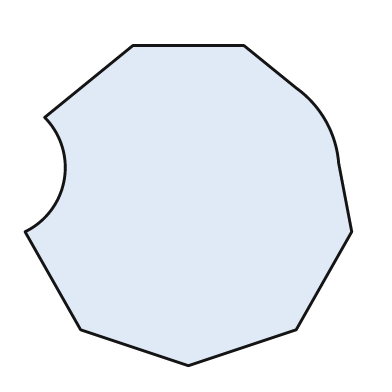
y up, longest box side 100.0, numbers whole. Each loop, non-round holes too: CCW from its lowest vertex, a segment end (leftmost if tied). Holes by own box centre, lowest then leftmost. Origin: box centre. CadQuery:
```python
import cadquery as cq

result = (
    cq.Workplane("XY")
    .moveTo(0.0, -49.0)
    .lineTo(33.0, -38.0)
    .lineTo(50.0, -8.0)
    .lineTo(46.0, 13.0)
    .threePointArc((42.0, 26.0), (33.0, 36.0))
    .lineTo(17.0, 49.0)
    .lineTo(-17.0, 49.0)
    .lineTo(-44.0, 27.0)
    .threePointArc((-38.0, 8.0), (-50.0, -8.0))
    .lineTo(-33.0, -38.0)
    .close()
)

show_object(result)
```